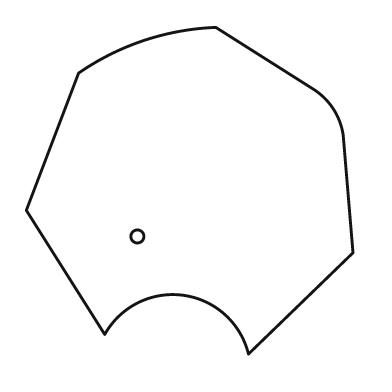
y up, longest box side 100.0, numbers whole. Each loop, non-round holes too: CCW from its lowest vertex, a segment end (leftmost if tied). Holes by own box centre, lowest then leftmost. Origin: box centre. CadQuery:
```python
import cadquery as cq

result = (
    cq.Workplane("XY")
    .moveTo(18.0, -50.0)
    .lineTo(50.0, -19.0)
    .lineTo(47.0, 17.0)
    .threePointArc((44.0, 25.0), (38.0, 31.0))
    .lineTo(8.0, 50.0)
    .threePointArc((-14.0, 46.0), (-34.0, 36.0))
    .lineTo(-50.0, -6.0)
    .lineTo(-26.0, -44.0)
    .threePointArc((-2.0, -32.0), (18.0, -50.0))
    .close()
    .moveTo(-16.0, -14.0)
    .circle(2.0)
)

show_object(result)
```